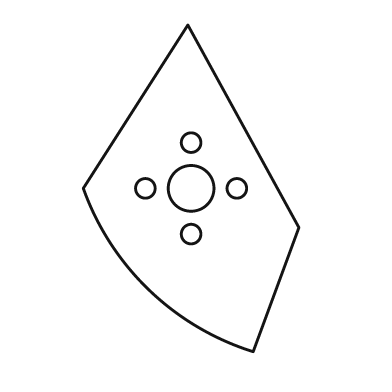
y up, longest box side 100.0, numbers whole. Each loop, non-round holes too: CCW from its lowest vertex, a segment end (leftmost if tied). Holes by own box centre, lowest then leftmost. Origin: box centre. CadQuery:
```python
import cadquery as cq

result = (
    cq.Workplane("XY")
    .moveTo(19.0, -50.0)
    .lineTo(33.0, -12.0)
    .lineTo(-1.0, 50.0)
    .lineTo(-33.0, 0.0)
    .threePointArc((-13.0, -31.0), (19.0, -50.0))
    .close()
    .moveTo(0.0, -14.0)
    .circle(3.0)
    .moveTo(-14.0, 0.0)
    .circle(3.0)
    .moveTo(0.0, 0.0)
    .circle(7.0)
    .moveTo(14.0, 0.0)
    .circle(3.0)
    .moveTo(0.0, 14.0)
    .circle(3.0)
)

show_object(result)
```